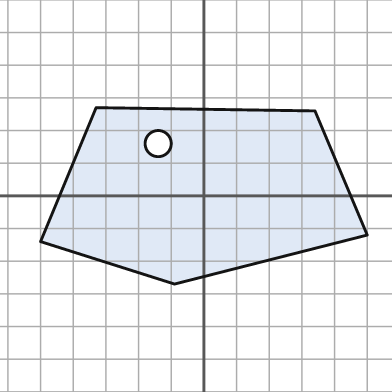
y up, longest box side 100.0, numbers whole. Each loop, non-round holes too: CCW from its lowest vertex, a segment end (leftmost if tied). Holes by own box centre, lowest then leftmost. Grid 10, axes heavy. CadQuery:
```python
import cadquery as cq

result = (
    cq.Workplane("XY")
    .moveTo(-9.0, -27.0)
    .lineTo(50.0, -12.0)
    .lineTo(34.0, 26.0)
    .lineTo(-33.0, 27.0)
    .lineTo(-50.0, -14.0)
    .close()
    .moveTo(-14.0, 16.0)
    .circle(4.0)
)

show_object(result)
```